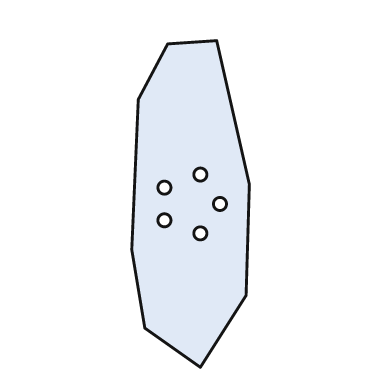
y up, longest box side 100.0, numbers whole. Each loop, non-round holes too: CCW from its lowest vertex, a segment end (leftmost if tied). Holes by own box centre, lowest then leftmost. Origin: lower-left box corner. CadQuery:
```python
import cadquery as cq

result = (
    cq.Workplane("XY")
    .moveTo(21.0, 0.0)
    .lineTo(35.0, 22.0)
    .lineTo(36.0, 56.0)
    .lineTo(26.0, 100.0)
    .lineTo(11.0, 99.0)
    .lineTo(2.0, 82.0)
    .lineTo(0.0, 36.0)
    .lineTo(4.0, 12.0)
    .close()
    .moveTo(21.0, 41.0)
    .circle(2.0)
    .moveTo(10.0, 45.0)
    .circle(2.0)
    .moveTo(27.0, 50.0)
    .circle(2.0)
    .moveTo(10.0, 55.0)
    .circle(2.0)
    .moveTo(21.0, 59.0)
    .circle(2.0)
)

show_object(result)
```